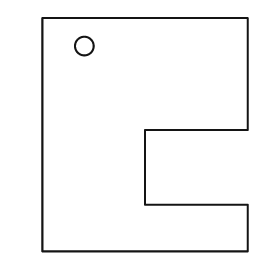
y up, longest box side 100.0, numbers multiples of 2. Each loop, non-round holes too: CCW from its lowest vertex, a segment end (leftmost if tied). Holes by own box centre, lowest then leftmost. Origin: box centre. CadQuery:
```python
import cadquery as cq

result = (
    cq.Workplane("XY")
    .moveTo(-44.0, -50.0)
    .lineTo(44.0, -50.0)
    .lineTo(44.0, -30.0)
    .lineTo(0.0, -30.0)
    .lineTo(0.0, 2.0)
    .lineTo(44.0, 2.0)
    .lineTo(44.0, 50.0)
    .lineTo(-44.0, 50.0)
    .close()
    .moveTo(-26.0, 38.0)
    .circle(4.0)
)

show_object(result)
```